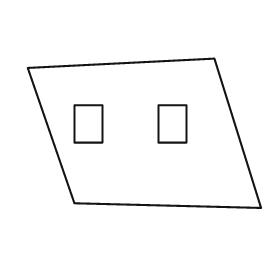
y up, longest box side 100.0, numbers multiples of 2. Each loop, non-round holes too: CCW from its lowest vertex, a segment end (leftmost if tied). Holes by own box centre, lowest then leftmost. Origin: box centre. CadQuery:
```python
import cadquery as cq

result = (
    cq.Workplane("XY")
    .moveTo(50.0, -32.0)
    .lineTo(30.0, 32.0)
    .lineTo(-50.0, 28.0)
    .lineTo(-30.0, -30.0)
    .close()
    .moveTo(-30.0, -4.0)
    .lineTo(-18.0, -4.0)
    .lineTo(-18.0, 12.0)
    .lineTo(-30.0, 12.0)
    .close()
    .moveTo(6.0, -4.0)
    .lineTo(18.0, -4.0)
    .lineTo(18.0, 12.0)
    .lineTo(6.0, 12.0)
    .close()
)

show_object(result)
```